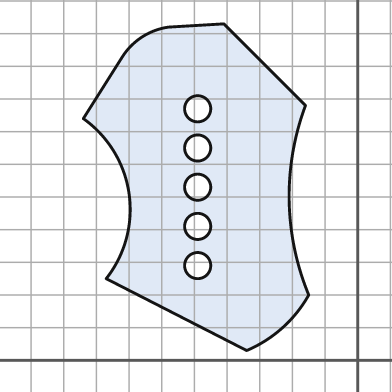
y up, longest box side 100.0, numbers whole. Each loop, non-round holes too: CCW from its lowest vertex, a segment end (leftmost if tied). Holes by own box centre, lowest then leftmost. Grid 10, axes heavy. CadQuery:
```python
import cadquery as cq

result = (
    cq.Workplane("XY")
    .moveTo(-34.0, 3.0)
    .threePointArc((-23.0, 10.0), (-15.0, 20.0))
    .threePointArc((-21.0, 49.0), (-16.0, 78.0))
    .lineTo(-41.0, 103.0)
    .lineTo(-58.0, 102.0)
    .threePointArc((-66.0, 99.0), (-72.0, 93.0))
    .lineTo(-84.0, 74.0)
    .threePointArc((-70.0, 51.0), (-77.0, 25.0))
    .close()
    .moveTo(-49.0, 29.0)
    .circle(4.0)
    .moveTo(-49.0, 41.0)
    .circle(4.0)
    .moveTo(-49.0, 53.0)
    .circle(4.0)
    .moveTo(-49.0, 65.0)
    .circle(4.0)
    .moveTo(-49.0, 77.0)
    .circle(4.0)
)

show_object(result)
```